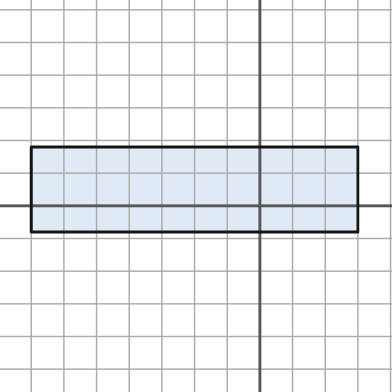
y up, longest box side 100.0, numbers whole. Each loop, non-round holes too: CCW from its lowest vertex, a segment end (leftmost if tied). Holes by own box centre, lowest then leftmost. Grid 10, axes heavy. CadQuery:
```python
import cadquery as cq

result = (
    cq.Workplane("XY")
    .moveTo(-70.0, -8.0)
    .lineTo(30.0, -8.0)
    .lineTo(30.0, 18.0)
    .lineTo(-70.0, 18.0)
    .close()
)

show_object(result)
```